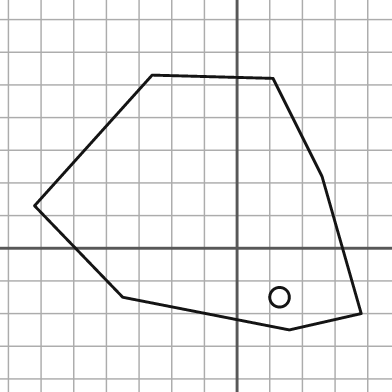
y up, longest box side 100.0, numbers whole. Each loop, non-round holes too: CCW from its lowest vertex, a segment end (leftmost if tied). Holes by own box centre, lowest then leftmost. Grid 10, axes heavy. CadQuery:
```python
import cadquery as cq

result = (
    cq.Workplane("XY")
    .moveTo(16.0, -25.0)
    .lineTo(38.0, -20.0)
    .lineTo(26.0, 22.0)
    .lineTo(11.0, 52.0)
    .lineTo(-26.0, 53.0)
    .lineTo(-62.0, 13.0)
    .lineTo(-35.0, -15.0)
    .close()
    .moveTo(13.0, -15.0)
    .circle(3.0)
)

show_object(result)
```